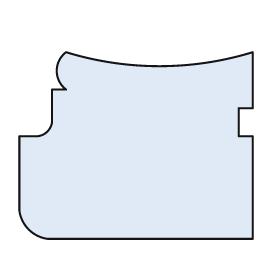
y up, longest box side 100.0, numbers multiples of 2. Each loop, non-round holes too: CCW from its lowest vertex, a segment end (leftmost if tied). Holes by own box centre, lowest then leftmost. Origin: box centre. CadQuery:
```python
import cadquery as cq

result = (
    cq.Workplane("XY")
    .moveTo(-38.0, -40.0)
    .lineTo(50.0, -40.0)
    .lineTo(50.0, 4.0)
    .lineTo(44.0, 4.0)
    .lineTo(44.0, 16.0)
    .lineTo(50.0, 16.0)
    .lineTo(50.0, 40.0)
    .threePointArc((10.0, 34.0), (-30.0, 40.0))
    .threePointArc((-34.0, 32.0), (-30.0, 24.0))
    .lineTo(-36.0, 24.0)
    .lineTo(-36.0, 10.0)
    .threePointArc((-38.0, 6.0), (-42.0, 4.0))
    .lineTo(-50.0, 4.0)
    .lineTo(-50.0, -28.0)
    .threePointArc((-46.0, -36.0), (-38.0, -40.0))
    .close()
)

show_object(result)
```